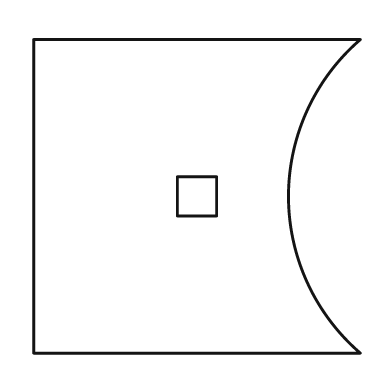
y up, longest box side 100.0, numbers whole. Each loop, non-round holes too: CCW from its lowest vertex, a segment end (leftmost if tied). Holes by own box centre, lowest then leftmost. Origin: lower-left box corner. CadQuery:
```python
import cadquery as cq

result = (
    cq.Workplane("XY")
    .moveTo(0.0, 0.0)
    .lineTo(100.0, 0.0)
    .threePointArc((78.0, 48.0), (100.0, 96.0))
    .lineTo(0.0, 96.0)
    .close()
    .moveTo(44.0, 42.0)
    .lineTo(56.0, 42.0)
    .lineTo(56.0, 54.0)
    .lineTo(44.0, 54.0)
    .close()
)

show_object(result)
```